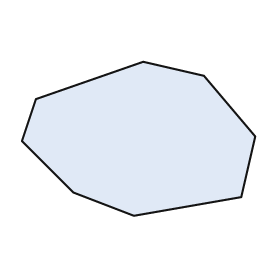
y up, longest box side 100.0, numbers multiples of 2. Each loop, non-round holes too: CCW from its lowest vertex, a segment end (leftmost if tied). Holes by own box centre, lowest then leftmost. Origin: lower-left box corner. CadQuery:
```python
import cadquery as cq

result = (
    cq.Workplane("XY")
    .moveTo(48.0, 0.0)
    .lineTo(94.0, 8.0)
    .lineTo(100.0, 34.0)
    .lineTo(78.0, 60.0)
    .lineTo(52.0, 66.0)
    .lineTo(6.0, 50.0)
    .lineTo(0.0, 32.0)
    .lineTo(22.0, 10.0)
    .close()
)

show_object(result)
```